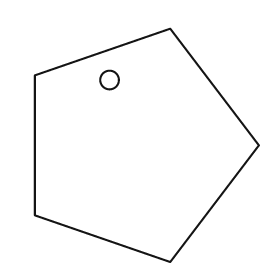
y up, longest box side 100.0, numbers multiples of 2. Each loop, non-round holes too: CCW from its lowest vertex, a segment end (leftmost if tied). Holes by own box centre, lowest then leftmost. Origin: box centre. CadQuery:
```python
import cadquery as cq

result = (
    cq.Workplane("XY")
    .moveTo(10.0, -50.0)
    .lineTo(48.0, 0.0)
    .lineTo(10.0, 50.0)
    .lineTo(-48.0, 30.0)
    .lineTo(-48.0, -30.0)
    .close()
    .moveTo(-16.0, 28.0)
    .circle(4.0)
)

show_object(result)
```